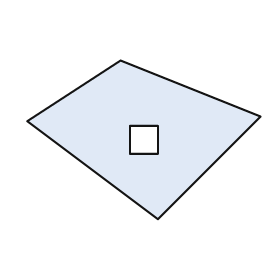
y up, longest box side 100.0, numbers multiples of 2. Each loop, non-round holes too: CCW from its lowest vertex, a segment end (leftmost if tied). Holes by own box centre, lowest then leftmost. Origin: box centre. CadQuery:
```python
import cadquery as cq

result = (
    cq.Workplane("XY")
    .moveTo(6.0, -34.0)
    .lineTo(50.0, 10.0)
    .lineTo(-10.0, 34.0)
    .lineTo(-50.0, 8.0)
    .close()
    .moveTo(-6.0, -6.0)
    .lineTo(6.0, -6.0)
    .lineTo(6.0, 6.0)
    .lineTo(-6.0, 6.0)
    .close()
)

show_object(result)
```